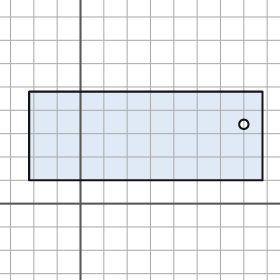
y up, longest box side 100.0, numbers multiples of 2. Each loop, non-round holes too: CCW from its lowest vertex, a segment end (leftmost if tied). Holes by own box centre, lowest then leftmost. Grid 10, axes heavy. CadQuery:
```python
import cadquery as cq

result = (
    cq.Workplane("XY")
    .moveTo(-22.0, 10.0)
    .lineTo(78.0, 10.0)
    .lineTo(78.0, 48.0)
    .lineTo(-22.0, 48.0)
    .close()
    .moveTo(70.0, 34.0)
    .circle(2.0)
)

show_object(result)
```